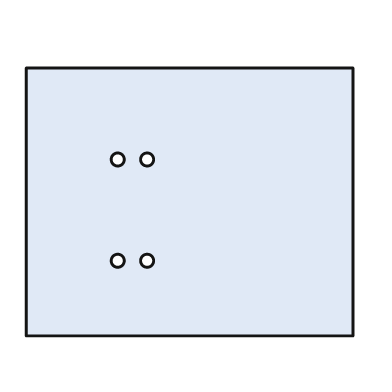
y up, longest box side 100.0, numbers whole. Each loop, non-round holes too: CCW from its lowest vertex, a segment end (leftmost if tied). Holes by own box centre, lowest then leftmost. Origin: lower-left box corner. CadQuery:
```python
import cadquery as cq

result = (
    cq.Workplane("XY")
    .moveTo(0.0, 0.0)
    .lineTo(100.0, 0.0)
    .lineTo(100.0, 82.0)
    .lineTo(0.0, 82.0)
    .close()
    .moveTo(28.0, 23.0)
    .circle(2.0)
    .moveTo(37.0, 23.0)
    .circle(2.0)
    .moveTo(28.0, 54.0)
    .circle(2.0)
    .moveTo(37.0, 54.0)
    .circle(2.0)
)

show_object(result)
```